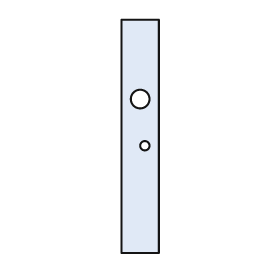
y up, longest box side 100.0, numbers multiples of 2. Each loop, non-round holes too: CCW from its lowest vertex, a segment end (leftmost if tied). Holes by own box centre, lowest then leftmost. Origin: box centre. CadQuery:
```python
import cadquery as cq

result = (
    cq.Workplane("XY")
    .moveTo(-8.0, -50.0)
    .lineTo(8.0, -50.0)
    .lineTo(8.0, 50.0)
    .lineTo(-8.0, 50.0)
    .close()
    .moveTo(2.0, -4.0)
    .circle(2.0)
    .moveTo(0.0, 16.0)
    .circle(4.0)
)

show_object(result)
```